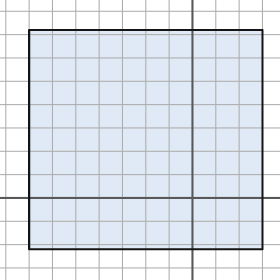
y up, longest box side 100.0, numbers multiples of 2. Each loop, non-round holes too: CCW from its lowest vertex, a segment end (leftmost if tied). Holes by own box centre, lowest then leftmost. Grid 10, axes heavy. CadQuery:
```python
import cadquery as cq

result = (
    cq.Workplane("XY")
    .moveTo(-70.0, -22.0)
    .lineTo(30.0, -22.0)
    .lineTo(30.0, 72.0)
    .lineTo(-70.0, 72.0)
    .close()
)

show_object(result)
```